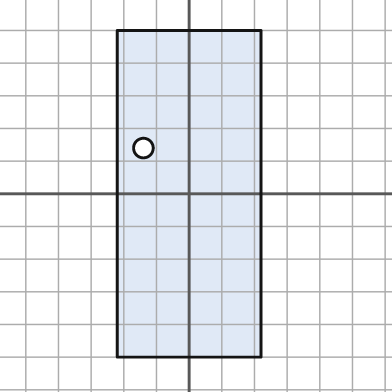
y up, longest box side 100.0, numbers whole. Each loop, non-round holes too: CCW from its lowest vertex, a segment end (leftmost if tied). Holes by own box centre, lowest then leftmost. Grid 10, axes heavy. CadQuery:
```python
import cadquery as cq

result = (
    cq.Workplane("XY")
    .moveTo(-22.0, -50.0)
    .lineTo(22.0, -50.0)
    .lineTo(22.0, 50.0)
    .lineTo(-22.0, 50.0)
    .close()
    .moveTo(-14.0, 14.0)
    .circle(3.0)
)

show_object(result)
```